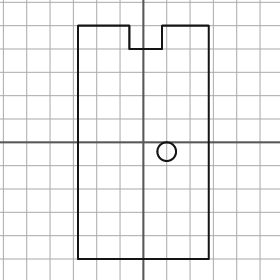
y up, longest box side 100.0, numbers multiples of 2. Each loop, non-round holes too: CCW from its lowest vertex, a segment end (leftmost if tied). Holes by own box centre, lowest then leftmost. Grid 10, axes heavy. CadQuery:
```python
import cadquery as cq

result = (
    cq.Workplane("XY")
    .moveTo(-28.0, -50.0)
    .lineTo(28.0, -50.0)
    .lineTo(28.0, 50.0)
    .lineTo(8.0, 50.0)
    .lineTo(8.0, 40.0)
    .lineTo(-6.0, 40.0)
    .lineTo(-6.0, 50.0)
    .lineTo(-28.0, 50.0)
    .close()
    .moveTo(10.0, -4.0)
    .circle(4.0)
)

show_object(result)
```